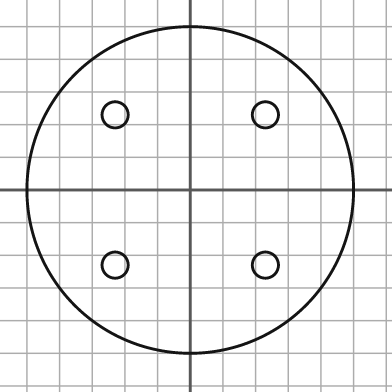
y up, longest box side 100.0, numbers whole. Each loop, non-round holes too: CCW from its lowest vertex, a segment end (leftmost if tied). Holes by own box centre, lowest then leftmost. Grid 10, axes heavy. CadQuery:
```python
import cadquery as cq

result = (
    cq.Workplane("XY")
    .moveTo(0.0, 0.0)
    .circle(50.0)
    .moveTo(-23.0, -23.0)
    .circle(4.0)
    .moveTo(23.0, -23.0)
    .circle(4.0)
    .moveTo(-23.0, 23.0)
    .circle(4.0)
    .moveTo(23.0, 23.0)
    .circle(4.0)
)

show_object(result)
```